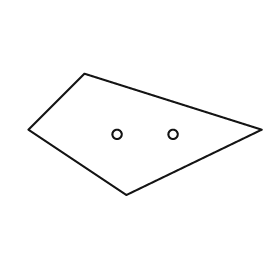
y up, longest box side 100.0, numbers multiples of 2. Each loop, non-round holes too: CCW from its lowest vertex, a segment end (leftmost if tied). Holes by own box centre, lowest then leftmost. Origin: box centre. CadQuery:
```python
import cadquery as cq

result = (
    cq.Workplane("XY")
    .moveTo(-8.0, -26.0)
    .lineTo(50.0, 2.0)
    .lineTo(-26.0, 26.0)
    .lineTo(-50.0, 2.0)
    .close()
    .moveTo(-12.0, 0.0)
    .circle(2.0)
    .moveTo(12.0, 0.0)
    .circle(2.0)
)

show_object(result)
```